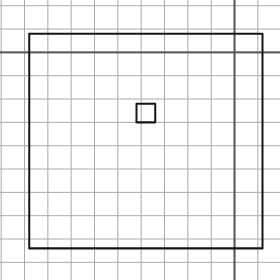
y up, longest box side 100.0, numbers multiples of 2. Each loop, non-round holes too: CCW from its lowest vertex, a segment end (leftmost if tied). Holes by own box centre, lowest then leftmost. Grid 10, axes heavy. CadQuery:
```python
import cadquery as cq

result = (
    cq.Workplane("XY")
    .moveTo(-88.0, -84.0)
    .lineTo(12.0, -84.0)
    .lineTo(12.0, 8.0)
    .lineTo(-88.0, 8.0)
    .close()
    .moveTo(-42.0, -30.0)
    .lineTo(-34.0, -30.0)
    .lineTo(-34.0, -22.0)
    .lineTo(-42.0, -22.0)
    .close()
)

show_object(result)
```